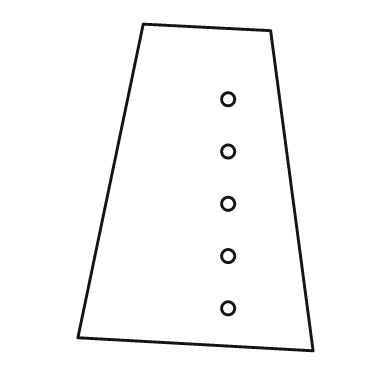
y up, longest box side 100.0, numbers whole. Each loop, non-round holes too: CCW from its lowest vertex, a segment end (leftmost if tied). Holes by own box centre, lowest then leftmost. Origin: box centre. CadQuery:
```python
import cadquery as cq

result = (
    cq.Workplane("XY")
    .moveTo(36.0, -50.0)
    .lineTo(23.0, 48.0)
    .lineTo(-16.0, 50.0)
    .lineTo(-36.0, -46.0)
    .close()
    .moveTo(10.0, -37.0)
    .circle(2.0)
    .moveTo(10.0, -21.0)
    .circle(2.0)
    .moveTo(10.0, -5.0)
    .circle(2.0)
    .moveTo(10.0, 11.0)
    .circle(2.0)
    .moveTo(10.0, 27.0)
    .circle(2.0)
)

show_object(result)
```